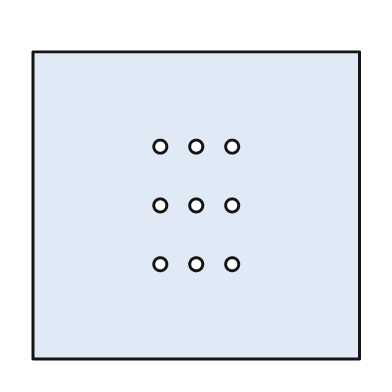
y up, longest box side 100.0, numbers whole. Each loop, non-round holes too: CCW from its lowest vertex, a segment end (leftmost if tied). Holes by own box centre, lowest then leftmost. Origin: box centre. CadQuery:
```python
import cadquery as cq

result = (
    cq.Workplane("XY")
    .moveTo(-50.0, -47.0)
    .lineTo(50.0, -47.0)
    .lineTo(50.0, 47.0)
    .lineTo(-50.0, 47.0)
    .close()
    .moveTo(-11.0, -18.0)
    .circle(2.0)
    .moveTo(0.0, -18.0)
    .circle(2.0)
    .moveTo(11.0, -18.0)
    .circle(2.0)
    .moveTo(-11.0, 0.0)
    .circle(2.0)
    .moveTo(0.0, 0.0)
    .circle(2.0)
    .moveTo(11.0, 0.0)
    .circle(2.0)
    .moveTo(-11.0, 18.0)
    .circle(2.0)
    .moveTo(0.0, 18.0)
    .circle(2.0)
    .moveTo(11.0, 18.0)
    .circle(2.0)
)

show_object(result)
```